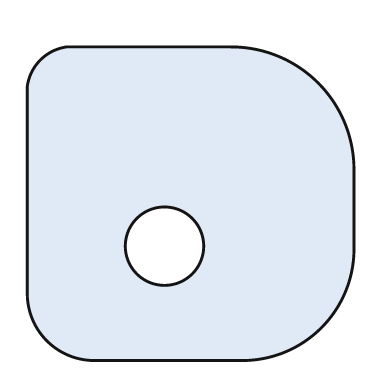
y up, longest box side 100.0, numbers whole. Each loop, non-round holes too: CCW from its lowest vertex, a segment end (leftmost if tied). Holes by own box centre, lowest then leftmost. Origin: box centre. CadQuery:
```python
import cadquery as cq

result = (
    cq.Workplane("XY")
    .moveTo(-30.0, -48.0)
    .lineTo(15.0, -48.0)
    .threePointArc((40.0, -38.0), (50.0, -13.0))
    .lineTo(50.0, 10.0)
    .threePointArc((39.0, 37.0), (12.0, 48.0))
    .lineTo(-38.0, 48.0)
    .threePointArc((-46.0, 44.0), (-50.0, 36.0))
    .lineTo(-50.0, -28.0)
    .threePointArc((-44.0, -42.0), (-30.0, -48.0))
    .close()
    .moveTo(-8.0, -13.0)
    .circle(12.0)
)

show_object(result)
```